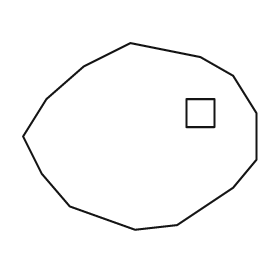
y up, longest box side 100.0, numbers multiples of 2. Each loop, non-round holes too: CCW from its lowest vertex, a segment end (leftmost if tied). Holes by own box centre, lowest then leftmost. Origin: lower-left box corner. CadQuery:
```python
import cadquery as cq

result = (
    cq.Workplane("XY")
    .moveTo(48.0, 0.0)
    .lineTo(66.0, 2.0)
    .lineTo(90.0, 18.0)
    .lineTo(100.0, 30.0)
    .lineTo(100.0, 50.0)
    .lineTo(90.0, 66.0)
    .lineTo(76.0, 74.0)
    .lineTo(46.0, 80.0)
    .lineTo(26.0, 70.0)
    .lineTo(10.0, 56.0)
    .lineTo(0.0, 40.0)
    .lineTo(8.0, 24.0)
    .lineTo(20.0, 10.0)
    .close()
    .moveTo(70.0, 44.0)
    .lineTo(82.0, 44.0)
    .lineTo(82.0, 56.0)
    .lineTo(70.0, 56.0)
    .close()
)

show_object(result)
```